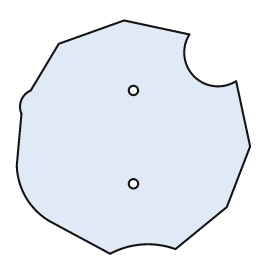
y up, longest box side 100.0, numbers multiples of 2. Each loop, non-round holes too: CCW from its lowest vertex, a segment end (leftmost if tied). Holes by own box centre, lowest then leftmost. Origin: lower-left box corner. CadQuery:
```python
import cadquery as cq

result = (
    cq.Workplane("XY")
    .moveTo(40.0, 0.0)
    .threePointArc((54.0, 4.0), (68.0, 2.0))
    .lineTo(90.0, 20.0)
    .lineTo(100.0, 46.0)
    .lineTo(94.0, 74.0)
    .threePointArc((76.0, 76.0), (74.0, 94.0))
    .lineTo(46.0, 100.0)
    .lineTo(18.0, 90.0)
    .lineTo(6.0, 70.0)
    .threePointArc((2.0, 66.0), (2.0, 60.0))
    .lineTo(0.0, 38.0)
    .threePointArc((4.0, 24.0), (14.0, 14.0))
    .close()
    .moveTo(50.0, 30.0)
    .circle(2.0)
    .moveTo(50.0, 70.0)
    .circle(2.0)
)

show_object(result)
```